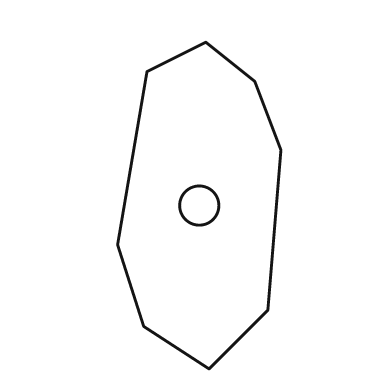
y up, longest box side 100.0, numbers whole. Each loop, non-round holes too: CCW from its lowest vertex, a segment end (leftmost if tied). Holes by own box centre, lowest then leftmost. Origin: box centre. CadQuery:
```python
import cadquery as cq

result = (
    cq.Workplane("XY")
    .moveTo(3.0, -50.0)
    .lineTo(21.0, -32.0)
    .lineTo(25.0, 17.0)
    .lineTo(17.0, 38.0)
    .lineTo(2.0, 50.0)
    .lineTo(-16.0, 41.0)
    .lineTo(-25.0, -12.0)
    .lineTo(-17.0, -37.0)
    .close()
    .moveTo(0.0, 0.0)
    .circle(6.0)
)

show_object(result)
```